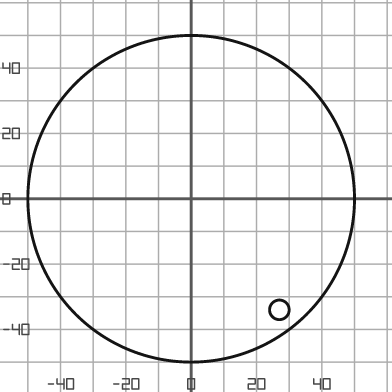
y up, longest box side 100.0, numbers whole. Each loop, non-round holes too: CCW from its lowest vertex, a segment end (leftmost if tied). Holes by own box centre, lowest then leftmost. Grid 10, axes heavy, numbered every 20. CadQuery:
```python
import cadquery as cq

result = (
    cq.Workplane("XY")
    .moveTo(0.0, 0.0)
    .circle(50.0)
    .moveTo(27.0, -34.0)
    .circle(3.0)
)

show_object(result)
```